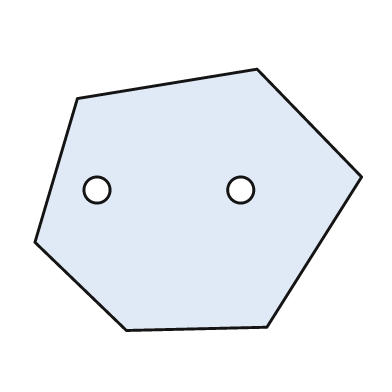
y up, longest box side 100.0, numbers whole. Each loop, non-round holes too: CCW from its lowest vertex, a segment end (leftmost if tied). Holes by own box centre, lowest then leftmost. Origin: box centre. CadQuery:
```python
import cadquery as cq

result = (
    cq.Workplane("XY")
    .moveTo(-22.0, -40.0)
    .lineTo(21.0, -39.0)
    .lineTo(50.0, 7.0)
    .lineTo(18.0, 40.0)
    .lineTo(-37.0, 31.0)
    .lineTo(-50.0, -13.0)
    .close()
    .moveTo(-31.0, 3.0)
    .circle(4.0)
    .moveTo(13.0, 3.0)
    .circle(4.0)
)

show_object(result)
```